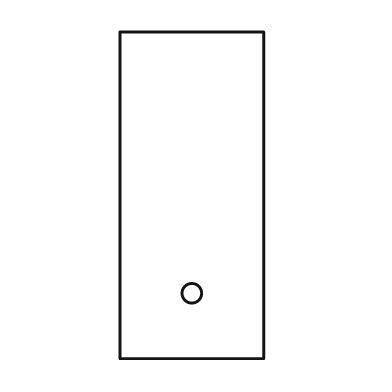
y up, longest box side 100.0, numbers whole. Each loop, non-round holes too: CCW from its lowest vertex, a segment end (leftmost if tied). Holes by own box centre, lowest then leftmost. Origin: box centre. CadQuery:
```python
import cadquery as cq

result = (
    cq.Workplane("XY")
    .moveTo(-22.0, -50.0)
    .lineTo(22.0, -50.0)
    .lineTo(22.0, 50.0)
    .lineTo(-22.0, 50.0)
    .close()
    .moveTo(0.0, -30.0)
    .circle(3.0)
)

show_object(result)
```